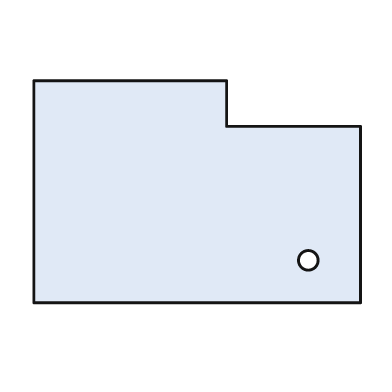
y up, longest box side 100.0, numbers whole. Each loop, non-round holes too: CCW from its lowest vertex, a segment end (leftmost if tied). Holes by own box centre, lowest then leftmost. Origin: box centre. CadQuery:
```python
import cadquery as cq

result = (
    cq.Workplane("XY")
    .moveTo(-50.0, -34.0)
    .lineTo(50.0, -34.0)
    .lineTo(50.0, 20.0)
    .lineTo(9.0, 20.0)
    .lineTo(9.0, 34.0)
    .lineTo(-50.0, 34.0)
    .close()
    .moveTo(34.0, -21.0)
    .circle(3.0)
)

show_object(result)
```